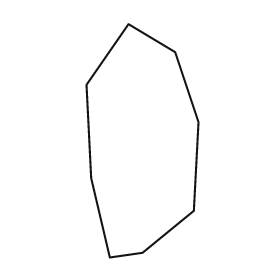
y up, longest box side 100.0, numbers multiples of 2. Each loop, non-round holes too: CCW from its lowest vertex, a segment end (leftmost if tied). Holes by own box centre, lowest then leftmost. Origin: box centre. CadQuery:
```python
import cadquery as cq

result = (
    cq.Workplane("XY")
    .moveTo(-14.0, -50.0)
    .lineTo(0.0, -48.0)
    .lineTo(22.0, -30.0)
    .lineTo(24.0, 8.0)
    .lineTo(14.0, 38.0)
    .lineTo(-6.0, 50.0)
    .lineTo(-24.0, 24.0)
    .lineTo(-22.0, -16.0)
    .close()
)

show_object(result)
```